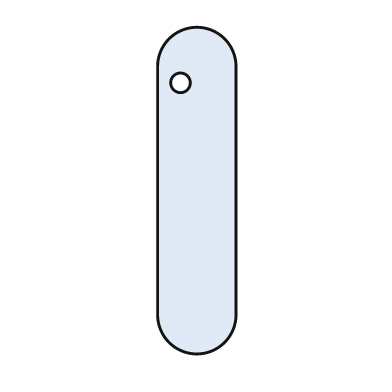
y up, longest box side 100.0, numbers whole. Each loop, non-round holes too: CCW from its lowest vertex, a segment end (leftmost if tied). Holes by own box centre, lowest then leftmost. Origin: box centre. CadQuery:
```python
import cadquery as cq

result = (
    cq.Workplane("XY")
    .moveTo(-12.0, -38.0)
    .threePointArc((0.0, -50.0), (12.0, -38.0))
    .lineTo(12.0, 38.0)
    .threePointArc((0.0, 50.0), (-12.0, 38.0))
    .close()
    .moveTo(-5.0, 33.0)
    .circle(3.0)
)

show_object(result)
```